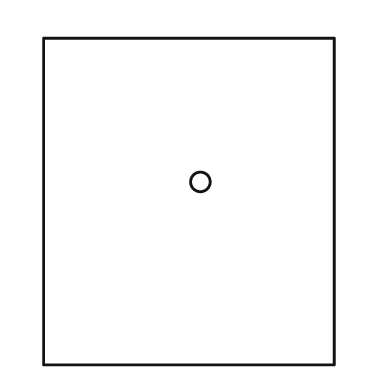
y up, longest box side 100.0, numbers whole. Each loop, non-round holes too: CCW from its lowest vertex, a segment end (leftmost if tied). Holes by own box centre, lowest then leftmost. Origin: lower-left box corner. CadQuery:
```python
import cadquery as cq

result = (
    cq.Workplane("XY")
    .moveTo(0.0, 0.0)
    .lineTo(89.0, 0.0)
    .lineTo(89.0, 100.0)
    .lineTo(0.0, 100.0)
    .close()
    .moveTo(48.0, 56.0)
    .circle(3.0)
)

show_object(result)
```